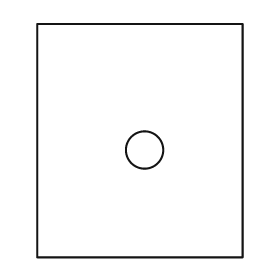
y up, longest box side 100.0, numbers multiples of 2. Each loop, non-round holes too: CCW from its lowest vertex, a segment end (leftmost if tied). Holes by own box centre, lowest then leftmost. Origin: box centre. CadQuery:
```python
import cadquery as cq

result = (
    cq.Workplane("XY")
    .moveTo(-44.0, -50.0)
    .lineTo(44.0, -50.0)
    .lineTo(44.0, 50.0)
    .lineTo(-44.0, 50.0)
    .close()
    .moveTo(2.0, -4.0)
    .circle(8.0)
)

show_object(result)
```